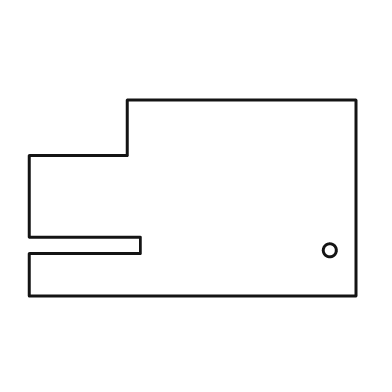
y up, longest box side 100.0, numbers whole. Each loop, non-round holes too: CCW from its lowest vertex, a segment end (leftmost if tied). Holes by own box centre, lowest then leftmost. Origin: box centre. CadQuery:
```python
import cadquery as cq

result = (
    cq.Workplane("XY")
    .moveTo(-50.0, -30.0)
    .lineTo(50.0, -30.0)
    .lineTo(50.0, 30.0)
    .lineTo(-20.0, 30.0)
    .lineTo(-20.0, 13.0)
    .lineTo(-50.0, 13.0)
    .lineTo(-50.0, -12.0)
    .lineTo(-16.0, -12.0)
    .lineTo(-16.0, -17.0)
    .lineTo(-50.0, -17.0)
    .close()
    .moveTo(42.0, -16.0)
    .circle(2.0)
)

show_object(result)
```